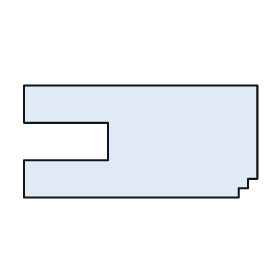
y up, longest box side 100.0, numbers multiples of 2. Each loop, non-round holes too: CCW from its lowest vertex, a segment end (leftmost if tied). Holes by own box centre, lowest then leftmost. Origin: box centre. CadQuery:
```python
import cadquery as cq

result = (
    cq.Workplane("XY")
    .moveTo(-50.0, -24.0)
    .lineTo(42.0, -24.0)
    .lineTo(42.0, -20.0)
    .lineTo(46.0, -20.0)
    .lineTo(46.0, -16.0)
    .lineTo(50.0, -16.0)
    .lineTo(50.0, 24.0)
    .lineTo(-50.0, 24.0)
    .lineTo(-50.0, 8.0)
    .lineTo(-14.0, 8.0)
    .lineTo(-14.0, -8.0)
    .lineTo(-50.0, -8.0)
    .close()
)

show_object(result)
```